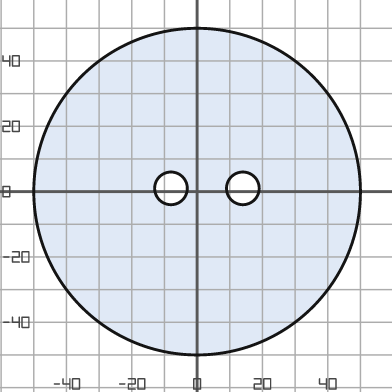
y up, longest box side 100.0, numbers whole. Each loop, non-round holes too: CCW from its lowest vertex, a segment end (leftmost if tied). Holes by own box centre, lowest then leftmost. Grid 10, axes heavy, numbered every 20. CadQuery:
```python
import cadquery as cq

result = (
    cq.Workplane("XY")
    .moveTo(0.0, 0.0)
    .circle(50.0)
    .moveTo(-8.0, 1.0)
    .circle(5.0)
    .moveTo(14.0, 1.0)
    .circle(5.0)
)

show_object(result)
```